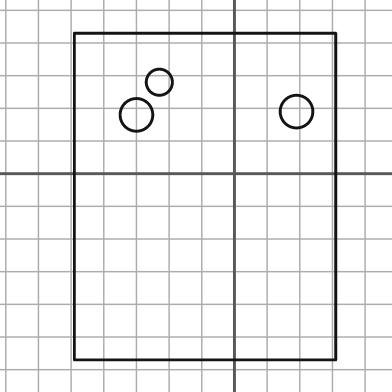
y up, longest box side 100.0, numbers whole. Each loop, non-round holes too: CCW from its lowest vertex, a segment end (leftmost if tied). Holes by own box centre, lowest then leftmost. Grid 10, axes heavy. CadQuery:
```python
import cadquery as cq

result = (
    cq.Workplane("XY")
    .moveTo(-49.0, -57.0)
    .lineTo(31.0, -57.0)
    .lineTo(31.0, 43.0)
    .lineTo(-49.0, 43.0)
    .close()
    .moveTo(-30.0, 18.0)
    .circle(5.0)
    .moveTo(19.0, 19.0)
    .circle(5.0)
    .moveTo(-23.0, 28.0)
    .circle(4.0)
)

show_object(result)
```